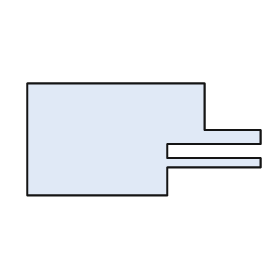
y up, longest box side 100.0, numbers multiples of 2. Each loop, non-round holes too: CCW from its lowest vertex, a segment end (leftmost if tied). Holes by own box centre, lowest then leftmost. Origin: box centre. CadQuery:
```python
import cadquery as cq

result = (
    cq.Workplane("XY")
    .moveTo(-50.0, -24.0)
    .lineTo(10.0, -24.0)
    .lineTo(10.0, -12.0)
    .lineTo(50.0, -12.0)
    .lineTo(50.0, -8.0)
    .lineTo(10.0, -8.0)
    .lineTo(10.0, -2.0)
    .lineTo(50.0, -2.0)
    .lineTo(50.0, 4.0)
    .lineTo(26.0, 4.0)
    .lineTo(26.0, 24.0)
    .lineTo(-50.0, 24.0)
    .close()
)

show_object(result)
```